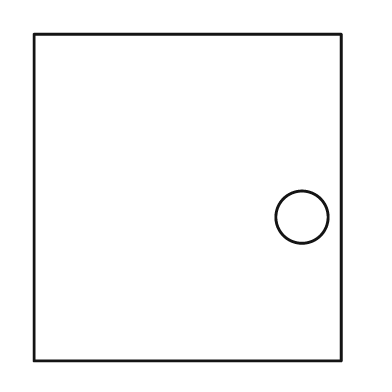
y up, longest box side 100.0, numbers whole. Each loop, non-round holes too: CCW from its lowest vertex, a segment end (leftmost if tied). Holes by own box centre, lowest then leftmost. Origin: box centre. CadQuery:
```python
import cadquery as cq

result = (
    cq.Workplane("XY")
    .moveTo(-47.0, -50.0)
    .lineTo(47.0, -50.0)
    .lineTo(47.0, 50.0)
    .lineTo(-47.0, 50.0)
    .close()
    .moveTo(35.0, -6.0)
    .circle(8.0)
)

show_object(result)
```